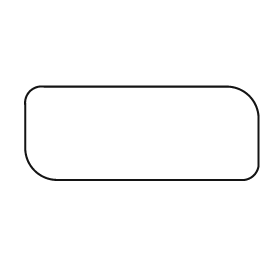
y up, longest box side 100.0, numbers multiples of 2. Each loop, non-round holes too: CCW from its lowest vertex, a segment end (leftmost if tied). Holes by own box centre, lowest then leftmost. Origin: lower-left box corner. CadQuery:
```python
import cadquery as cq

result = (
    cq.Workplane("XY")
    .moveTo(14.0, 0.0)
    .lineTo(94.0, 0.0)
    .threePointArc((98.0, 2.0), (100.0, 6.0))
    .lineTo(100.0, 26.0)
    .threePointArc((96.0, 36.0), (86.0, 40.0))
    .lineTo(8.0, 40.0)
    .threePointArc((2.0, 38.0), (0.0, 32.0))
    .lineTo(0.0, 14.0)
    .threePointArc((4.0, 4.0), (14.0, 0.0))
    .close()
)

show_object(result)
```